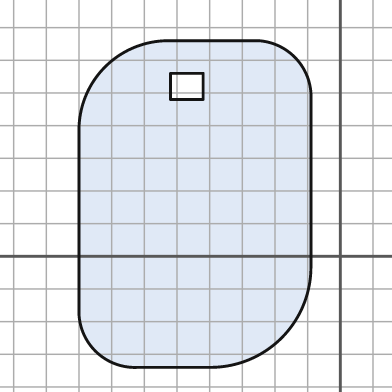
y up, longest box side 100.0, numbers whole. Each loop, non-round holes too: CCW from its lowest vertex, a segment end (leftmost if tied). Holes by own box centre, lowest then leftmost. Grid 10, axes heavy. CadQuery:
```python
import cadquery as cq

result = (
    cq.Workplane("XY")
    .moveTo(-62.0, -34.0)
    .lineTo(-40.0, -34.0)
    .threePointArc((-18.0, -25.0), (-9.0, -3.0))
    .lineTo(-9.0, 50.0)
    .threePointArc((-14.0, 61.0), (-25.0, 66.0))
    .lineTo(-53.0, 66.0)
    .threePointArc((-72.0, 58.0), (-80.0, 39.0))
    .lineTo(-80.0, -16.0)
    .threePointArc((-75.0, -29.0), (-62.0, -34.0))
    .close()
    .moveTo(-52.0, 48.0)
    .lineTo(-42.0, 48.0)
    .lineTo(-42.0, 56.0)
    .lineTo(-52.0, 56.0)
    .close()
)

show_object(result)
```